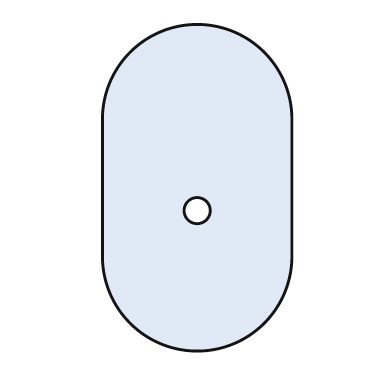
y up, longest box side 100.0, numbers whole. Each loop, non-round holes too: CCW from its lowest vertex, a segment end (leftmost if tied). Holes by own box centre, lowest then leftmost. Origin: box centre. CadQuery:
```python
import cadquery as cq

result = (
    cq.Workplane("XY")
    .moveTo(-29.0, -21.0)
    .threePointArc((0.0, -50.0), (29.0, -21.0))
    .lineTo(29.0, 21.0)
    .threePointArc((0.0, 50.0), (-29.0, 21.0))
    .close()
    .moveTo(0.0, -7.0)
    .circle(4.0)
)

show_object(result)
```